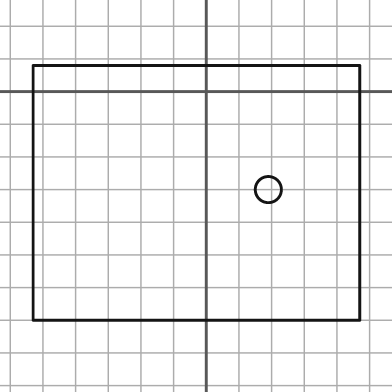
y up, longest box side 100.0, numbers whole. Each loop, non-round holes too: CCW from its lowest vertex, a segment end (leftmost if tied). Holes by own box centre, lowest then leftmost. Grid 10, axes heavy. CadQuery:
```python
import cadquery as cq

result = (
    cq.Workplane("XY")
    .moveTo(-53.0, -70.0)
    .lineTo(47.0, -70.0)
    .lineTo(47.0, 8.0)
    .lineTo(-53.0, 8.0)
    .close()
    .moveTo(19.0, -30.0)
    .circle(4.0)
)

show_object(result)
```